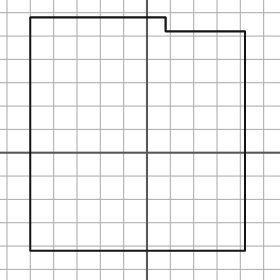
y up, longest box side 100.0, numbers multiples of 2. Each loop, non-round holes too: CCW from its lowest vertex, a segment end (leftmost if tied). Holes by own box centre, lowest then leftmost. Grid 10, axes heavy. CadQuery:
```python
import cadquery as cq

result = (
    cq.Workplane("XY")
    .moveTo(-50.0, -42.0)
    .lineTo(42.0, -42.0)
    .lineTo(42.0, 52.0)
    .lineTo(8.0, 52.0)
    .lineTo(8.0, 58.0)
    .lineTo(-50.0, 58.0)
    .close()
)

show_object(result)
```